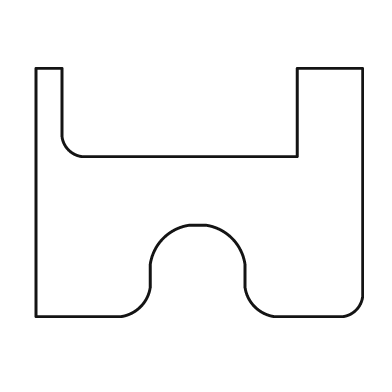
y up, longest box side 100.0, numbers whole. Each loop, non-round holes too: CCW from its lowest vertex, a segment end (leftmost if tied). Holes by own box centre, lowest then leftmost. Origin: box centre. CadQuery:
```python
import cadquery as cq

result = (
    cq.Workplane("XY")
    .moveTo(-50.0, -38.0)
    .lineTo(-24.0, -38.0)
    .threePointArc((-18.0, -35.0), (-15.0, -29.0))
    .lineTo(-15.0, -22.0)
    .threePointArc((-11.0, -14.0), (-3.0, -10.0))
    .lineTo(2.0, -10.0)
    .threePointArc((10.0, -14.0), (14.0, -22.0))
    .lineTo(14.0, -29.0)
    .threePointArc((17.0, -35.0), (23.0, -38.0))
    .lineTo(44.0, -38.0)
    .threePointArc((48.0, -36.0), (50.0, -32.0))
    .lineTo(50.0, 38.0)
    .lineTo(30.0, 38.0)
    .lineTo(30.0, 11.0)
    .lineTo(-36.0, 11.0)
    .threePointArc((-40.0, 13.0), (-42.0, 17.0))
    .lineTo(-42.0, 38.0)
    .lineTo(-50.0, 38.0)
    .close()
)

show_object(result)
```